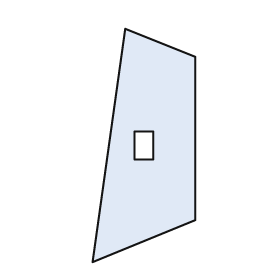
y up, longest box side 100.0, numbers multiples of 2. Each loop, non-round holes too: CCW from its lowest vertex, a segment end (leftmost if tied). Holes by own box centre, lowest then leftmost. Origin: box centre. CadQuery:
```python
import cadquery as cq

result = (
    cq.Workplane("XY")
    .moveTo(-22.0, -50.0)
    .lineTo(22.0, -32.0)
    .lineTo(22.0, 38.0)
    .lineTo(-8.0, 50.0)
    .close()
    .moveTo(-4.0, -6.0)
    .lineTo(4.0, -6.0)
    .lineTo(4.0, 6.0)
    .lineTo(-4.0, 6.0)
    .close()
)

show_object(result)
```